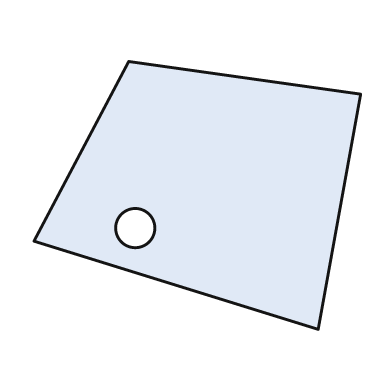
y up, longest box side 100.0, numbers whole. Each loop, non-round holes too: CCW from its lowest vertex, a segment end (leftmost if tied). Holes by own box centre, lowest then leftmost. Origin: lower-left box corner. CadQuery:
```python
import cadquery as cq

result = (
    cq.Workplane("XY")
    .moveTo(87.0, 0.0)
    .lineTo(100.0, 72.0)
    .lineTo(29.0, 82.0)
    .lineTo(0.0, 27.0)
    .close()
    .moveTo(31.0, 31.0)
    .circle(6.0)
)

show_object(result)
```